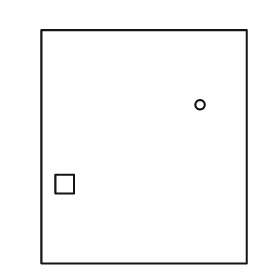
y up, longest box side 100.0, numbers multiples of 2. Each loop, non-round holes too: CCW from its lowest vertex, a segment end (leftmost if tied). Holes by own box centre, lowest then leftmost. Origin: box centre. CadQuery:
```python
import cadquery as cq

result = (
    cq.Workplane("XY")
    .moveTo(-44.0, -50.0)
    .lineTo(44.0, -50.0)
    .lineTo(44.0, 50.0)
    .lineTo(-44.0, 50.0)
    .close()
    .moveTo(-38.0, -20.0)
    .lineTo(-30.0, -20.0)
    .lineTo(-30.0, -12.0)
    .lineTo(-38.0, -12.0)
    .close()
    .moveTo(24.0, 18.0)
    .circle(2.0)
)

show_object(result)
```